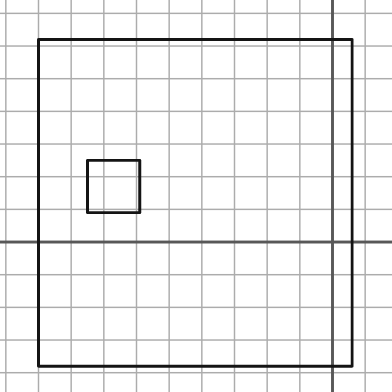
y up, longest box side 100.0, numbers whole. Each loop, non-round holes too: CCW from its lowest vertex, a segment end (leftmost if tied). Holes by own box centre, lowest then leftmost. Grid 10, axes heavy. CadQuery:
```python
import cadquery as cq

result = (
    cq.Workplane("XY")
    .moveTo(-90.0, -38.0)
    .lineTo(6.0, -38.0)
    .lineTo(6.0, 62.0)
    .lineTo(-90.0, 62.0)
    .close()
    .moveTo(-75.0, 9.0)
    .lineTo(-59.0, 9.0)
    .lineTo(-59.0, 25.0)
    .lineTo(-75.0, 25.0)
    .close()
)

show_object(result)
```